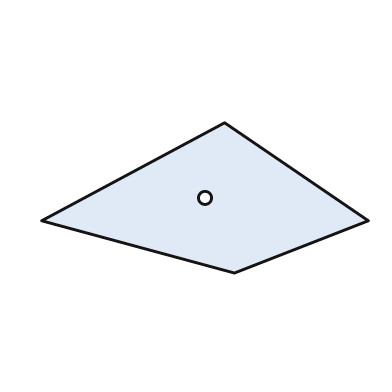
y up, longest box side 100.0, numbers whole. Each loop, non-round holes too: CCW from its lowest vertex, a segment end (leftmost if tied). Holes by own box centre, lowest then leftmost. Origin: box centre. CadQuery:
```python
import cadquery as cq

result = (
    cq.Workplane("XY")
    .moveTo(9.0, -23.0)
    .lineTo(50.0, -7.0)
    .lineTo(6.0, 23.0)
    .lineTo(-50.0, -7.0)
    .close()
    .moveTo(0.0, 0.0)
    .circle(2.0)
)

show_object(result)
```